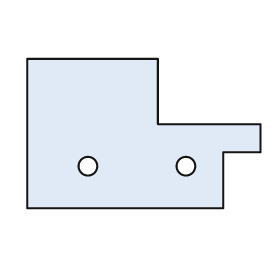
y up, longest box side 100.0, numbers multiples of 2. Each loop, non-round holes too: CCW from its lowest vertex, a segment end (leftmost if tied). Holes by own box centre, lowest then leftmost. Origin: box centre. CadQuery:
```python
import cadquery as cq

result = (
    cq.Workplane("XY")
    .moveTo(-50.0, -32.0)
    .lineTo(34.0, -32.0)
    .lineTo(34.0, -8.0)
    .lineTo(50.0, -8.0)
    .lineTo(50.0, 4.0)
    .lineTo(6.0, 4.0)
    .lineTo(6.0, 32.0)
    .lineTo(-50.0, 32.0)
    .close()
    .moveTo(-24.0, -14.0)
    .circle(4.0)
    .moveTo(18.0, -14.0)
    .circle(4.0)
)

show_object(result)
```